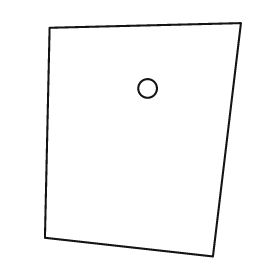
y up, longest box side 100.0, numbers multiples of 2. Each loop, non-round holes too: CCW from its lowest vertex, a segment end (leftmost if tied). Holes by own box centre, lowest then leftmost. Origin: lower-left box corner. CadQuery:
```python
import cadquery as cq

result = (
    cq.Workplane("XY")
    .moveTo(72.0, 0.0)
    .lineTo(84.0, 100.0)
    .lineTo(2.0, 98.0)
    .lineTo(0.0, 8.0)
    .close()
    .moveTo(44.0, 72.0)
    .circle(4.0)
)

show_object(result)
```